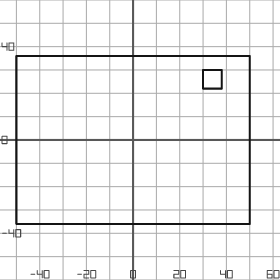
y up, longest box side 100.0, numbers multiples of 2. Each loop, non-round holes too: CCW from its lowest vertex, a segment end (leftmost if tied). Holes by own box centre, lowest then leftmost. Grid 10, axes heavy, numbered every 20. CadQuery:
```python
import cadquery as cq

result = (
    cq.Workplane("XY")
    .moveTo(-50.0, -36.0)
    .lineTo(50.0, -36.0)
    .lineTo(50.0, 36.0)
    .lineTo(-50.0, 36.0)
    .close()
    .moveTo(30.0, 22.0)
    .lineTo(38.0, 22.0)
    .lineTo(38.0, 30.0)
    .lineTo(30.0, 30.0)
    .close()
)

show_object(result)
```